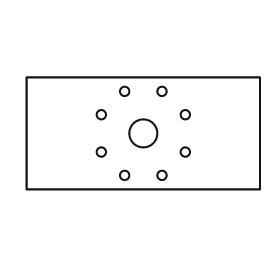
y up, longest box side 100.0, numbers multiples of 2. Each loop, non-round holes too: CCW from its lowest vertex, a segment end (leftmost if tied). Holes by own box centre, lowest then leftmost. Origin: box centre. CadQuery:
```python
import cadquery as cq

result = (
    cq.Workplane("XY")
    .moveTo(-50.0, -24.0)
    .lineTo(50.0, -24.0)
    .lineTo(50.0, 24.0)
    .lineTo(-50.0, 24.0)
    .close()
    .moveTo(-8.0, -18.0)
    .circle(2.0)
    .moveTo(8.0, -18.0)
    .circle(2.0)
    .moveTo(-18.0, -8.0)
    .circle(2.0)
    .moveTo(18.0, -8.0)
    .circle(2.0)
    .moveTo(0.0, 0.0)
    .circle(6.0)
    .moveTo(-18.0, 8.0)
    .circle(2.0)
    .moveTo(18.0, 8.0)
    .circle(2.0)
    .moveTo(-8.0, 18.0)
    .circle(2.0)
    .moveTo(8.0, 18.0)
    .circle(2.0)
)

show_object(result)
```